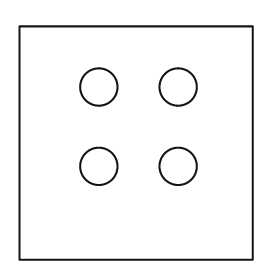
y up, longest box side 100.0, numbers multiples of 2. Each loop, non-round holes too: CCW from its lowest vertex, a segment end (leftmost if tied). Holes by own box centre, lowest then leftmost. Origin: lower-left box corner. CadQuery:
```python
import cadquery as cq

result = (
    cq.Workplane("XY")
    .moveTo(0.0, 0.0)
    .lineTo(100.0, 0.0)
    .lineTo(100.0, 100.0)
    .lineTo(0.0, 100.0)
    .close()
    .moveTo(34.0, 40.0)
    .circle(8.0)
    .moveTo(68.0, 40.0)
    .circle(8.0)
    .moveTo(34.0, 74.0)
    .circle(8.0)
    .moveTo(68.0, 74.0)
    .circle(8.0)
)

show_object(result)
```